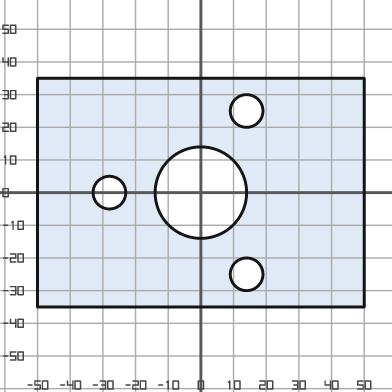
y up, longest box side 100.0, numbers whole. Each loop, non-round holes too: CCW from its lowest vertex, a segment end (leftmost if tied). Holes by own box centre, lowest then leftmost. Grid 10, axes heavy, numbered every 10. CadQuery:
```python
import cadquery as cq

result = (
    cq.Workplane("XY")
    .moveTo(-50.0, -35.0)
    .lineTo(50.0, -35.0)
    .lineTo(50.0, 35.0)
    .lineTo(-50.0, 35.0)
    .close()
    .moveTo(14.0, -25.0)
    .circle(5.0)
    .moveTo(-28.0, 0.0)
    .circle(5.0)
    .moveTo(0.0, 0.0)
    .circle(14.0)
    .moveTo(14.0, 25.0)
    .circle(5.0)
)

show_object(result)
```